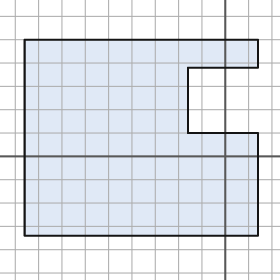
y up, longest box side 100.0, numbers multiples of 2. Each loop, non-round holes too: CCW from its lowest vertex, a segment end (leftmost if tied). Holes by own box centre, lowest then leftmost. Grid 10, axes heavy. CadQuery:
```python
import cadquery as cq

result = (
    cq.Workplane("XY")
    .moveTo(-86.0, -34.0)
    .lineTo(14.0, -34.0)
    .lineTo(14.0, 10.0)
    .lineTo(-16.0, 10.0)
    .lineTo(-16.0, 38.0)
    .lineTo(14.0, 38.0)
    .lineTo(14.0, 50.0)
    .lineTo(-86.0, 50.0)
    .close()
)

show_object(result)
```